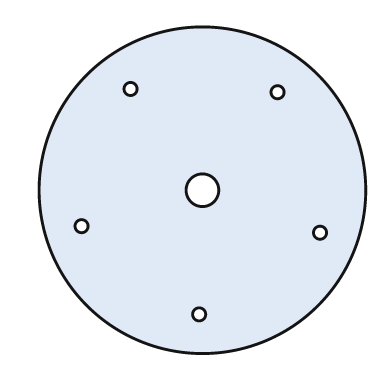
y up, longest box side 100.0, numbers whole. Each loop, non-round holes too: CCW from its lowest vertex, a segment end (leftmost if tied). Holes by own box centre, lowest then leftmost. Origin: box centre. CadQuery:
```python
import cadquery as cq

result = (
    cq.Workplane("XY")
    .moveTo(0.0, 0.0)
    .circle(50.0)
    .moveTo(-1.0, -38.0)
    .circle(2.0)
    .moveTo(36.0, -13.0)
    .circle(2.0)
    .moveTo(-37.0, -11.0)
    .circle(2.0)
    .moveTo(0.0, 0.0)
    .circle(5.0)
    .moveTo(23.0, 30.0)
    .circle(2.0)
    .moveTo(-22.0, 31.0)
    .circle(2.0)
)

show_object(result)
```